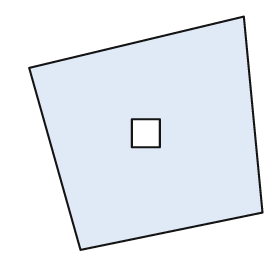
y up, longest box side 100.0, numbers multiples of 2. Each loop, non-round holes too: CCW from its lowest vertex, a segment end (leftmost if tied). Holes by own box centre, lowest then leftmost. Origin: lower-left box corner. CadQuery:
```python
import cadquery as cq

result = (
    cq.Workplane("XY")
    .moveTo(22.0, 0.0)
    .lineTo(100.0, 16.0)
    .lineTo(92.0, 100.0)
    .lineTo(0.0, 78.0)
    .close()
    .moveTo(44.0, 44.0)
    .lineTo(56.0, 44.0)
    .lineTo(56.0, 56.0)
    .lineTo(44.0, 56.0)
    .close()
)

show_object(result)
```